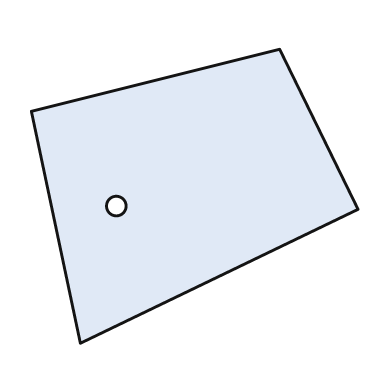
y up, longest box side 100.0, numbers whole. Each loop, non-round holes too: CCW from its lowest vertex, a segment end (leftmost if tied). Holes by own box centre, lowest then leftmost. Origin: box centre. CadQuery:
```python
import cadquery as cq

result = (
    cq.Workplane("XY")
    .moveTo(-35.0, -45.0)
    .lineTo(50.0, -4.0)
    .lineTo(26.0, 45.0)
    .lineTo(-50.0, 26.0)
    .close()
    .moveTo(-24.0, -3.0)
    .circle(3.0)
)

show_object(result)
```